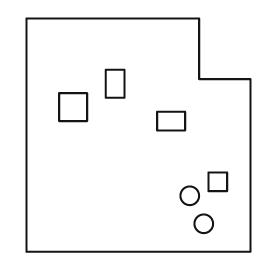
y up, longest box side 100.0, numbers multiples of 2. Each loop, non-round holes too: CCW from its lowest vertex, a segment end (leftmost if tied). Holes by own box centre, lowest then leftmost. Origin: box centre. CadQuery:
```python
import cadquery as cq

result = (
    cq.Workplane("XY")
    .moveTo(-48.0, -50.0)
    .lineTo(48.0, -50.0)
    .lineTo(48.0, 24.0)
    .lineTo(26.0, 24.0)
    .lineTo(26.0, 50.0)
    .lineTo(-48.0, 50.0)
    .close()
    .moveTo(28.0, -38.0)
    .circle(4.0)
    .moveTo(22.0, -26.0)
    .circle(4.0)
    .moveTo(30.0, -24.0)
    .lineTo(38.0, -24.0)
    .lineTo(38.0, -16.0)
    .lineTo(30.0, -16.0)
    .close()
    .moveTo(8.0, 2.0)
    .lineTo(20.0, 2.0)
    .lineTo(20.0, 10.0)
    .lineTo(8.0, 10.0)
    .close()
    .moveTo(-34.0, 6.0)
    .lineTo(-22.0, 6.0)
    .lineTo(-22.0, 18.0)
    .lineTo(-34.0, 18.0)
    .close()
    .moveTo(-14.0, 16.0)
    .lineTo(-6.0, 16.0)
    .lineTo(-6.0, 28.0)
    .lineTo(-14.0, 28.0)
    .close()
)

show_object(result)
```